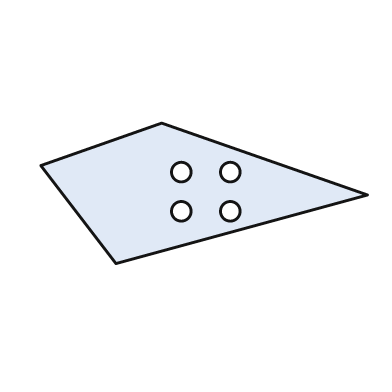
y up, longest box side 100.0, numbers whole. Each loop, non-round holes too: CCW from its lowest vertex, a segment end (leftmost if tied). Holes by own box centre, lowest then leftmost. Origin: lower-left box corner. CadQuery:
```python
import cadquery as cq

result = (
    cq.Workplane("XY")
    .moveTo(23.0, 0.0)
    .lineTo(100.0, 21.0)
    .lineTo(37.0, 43.0)
    .lineTo(0.0, 30.0)
    .close()
    .moveTo(43.0, 16.0)
    .circle(3.0)
    .moveTo(58.0, 16.0)
    .circle(3.0)
    .moveTo(43.0, 28.0)
    .circle(3.0)
    .moveTo(58.0, 28.0)
    .circle(3.0)
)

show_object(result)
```